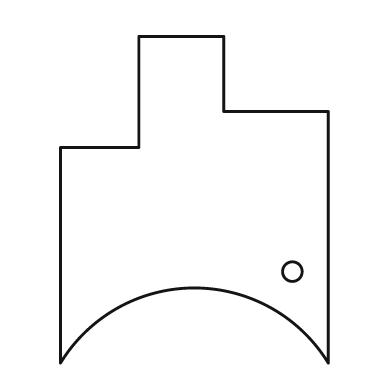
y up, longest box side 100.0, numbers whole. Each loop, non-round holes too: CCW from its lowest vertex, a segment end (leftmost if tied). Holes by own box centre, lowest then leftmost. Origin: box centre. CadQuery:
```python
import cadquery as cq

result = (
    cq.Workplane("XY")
    .moveTo(-41.0, -50.0)
    .threePointArc((0.0, -27.0), (41.0, -50.0))
    .lineTo(41.0, 27.0)
    .lineTo(9.0, 27.0)
    .lineTo(9.0, 50.0)
    .lineTo(-17.0, 50.0)
    .lineTo(-17.0, 16.0)
    .lineTo(-41.0, 16.0)
    .close()
    .moveTo(30.0, -22.0)
    .circle(3.0)
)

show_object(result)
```